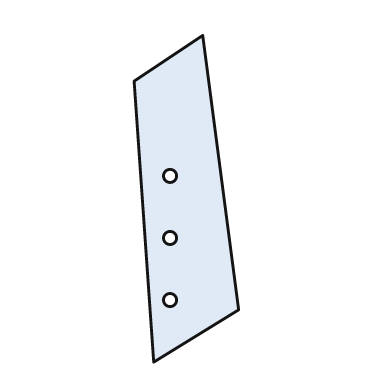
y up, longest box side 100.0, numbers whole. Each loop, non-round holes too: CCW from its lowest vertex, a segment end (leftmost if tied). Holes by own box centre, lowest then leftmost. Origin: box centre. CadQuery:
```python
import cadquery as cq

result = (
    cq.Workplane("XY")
    .moveTo(-10.0, -50.0)
    .lineTo(16.0, -34.0)
    .lineTo(5.0, 50.0)
    .lineTo(-16.0, 36.0)
    .close()
    .moveTo(-5.0, -31.0)
    .circle(2.0)
    .moveTo(-5.0, -12.0)
    .circle(2.0)
    .moveTo(-5.0, 7.0)
    .circle(2.0)
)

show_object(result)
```